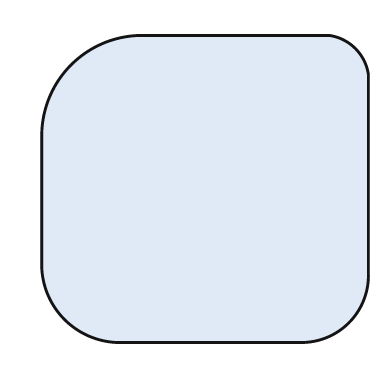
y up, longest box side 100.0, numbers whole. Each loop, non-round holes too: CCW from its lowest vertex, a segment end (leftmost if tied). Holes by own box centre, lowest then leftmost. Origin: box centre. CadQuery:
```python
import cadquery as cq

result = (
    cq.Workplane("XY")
    .moveTo(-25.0, -47.0)
    .lineTo(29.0, -47.0)
    .threePointArc((44.0, -41.0), (50.0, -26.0))
    .lineTo(50.0, 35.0)
    .threePointArc((46.0, 43.0), (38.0, 47.0))
    .lineTo(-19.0, 47.0)
    .threePointArc((-41.0, 38.0), (-50.0, 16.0))
    .lineTo(-50.0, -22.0)
    .threePointArc((-43.0, -40.0), (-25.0, -47.0))
    .close()
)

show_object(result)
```